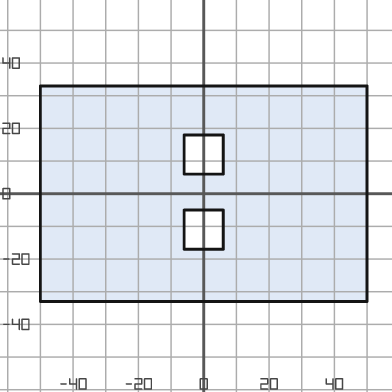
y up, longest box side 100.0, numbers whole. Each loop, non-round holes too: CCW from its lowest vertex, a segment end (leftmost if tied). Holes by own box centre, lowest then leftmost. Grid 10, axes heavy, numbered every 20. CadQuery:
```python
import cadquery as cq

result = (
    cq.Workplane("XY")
    .moveTo(-50.0, -33.0)
    .lineTo(50.0, -33.0)
    .lineTo(50.0, 33.0)
    .lineTo(-50.0, 33.0)
    .close()
    .moveTo(-6.0, -17.0)
    .lineTo(6.0, -17.0)
    .lineTo(6.0, -5.0)
    .lineTo(-6.0, -5.0)
    .close()
    .moveTo(-6.0, 6.0)
    .lineTo(6.0, 6.0)
    .lineTo(6.0, 18.0)
    .lineTo(-6.0, 18.0)
    .close()
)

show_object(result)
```